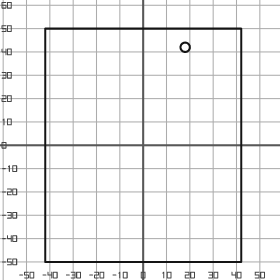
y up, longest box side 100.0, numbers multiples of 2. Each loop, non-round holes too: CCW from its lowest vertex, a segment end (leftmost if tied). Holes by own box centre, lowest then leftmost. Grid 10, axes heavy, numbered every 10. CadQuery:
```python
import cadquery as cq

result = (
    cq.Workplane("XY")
    .moveTo(-42.0, -50.0)
    .lineTo(42.0, -50.0)
    .lineTo(42.0, 50.0)
    .lineTo(-42.0, 50.0)
    .close()
    .moveTo(18.0, 42.0)
    .circle(2.0)
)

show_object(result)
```